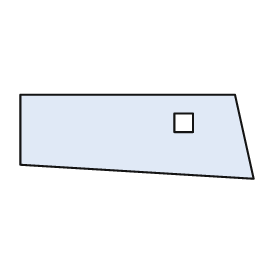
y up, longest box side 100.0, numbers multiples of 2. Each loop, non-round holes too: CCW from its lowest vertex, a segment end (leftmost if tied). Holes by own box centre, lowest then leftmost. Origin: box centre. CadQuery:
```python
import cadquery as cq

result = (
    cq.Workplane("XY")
    .moveTo(50.0, -18.0)
    .lineTo(42.0, 18.0)
    .lineTo(-50.0, 18.0)
    .lineTo(-50.0, -12.0)
    .close()
    .moveTo(16.0, 2.0)
    .lineTo(24.0, 2.0)
    .lineTo(24.0, 10.0)
    .lineTo(16.0, 10.0)
    .close()
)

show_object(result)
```